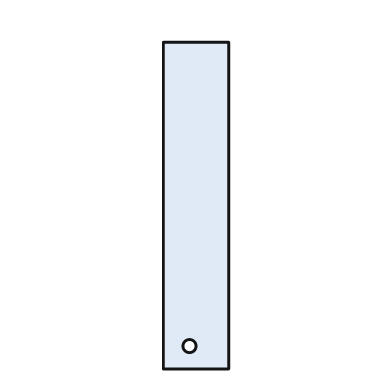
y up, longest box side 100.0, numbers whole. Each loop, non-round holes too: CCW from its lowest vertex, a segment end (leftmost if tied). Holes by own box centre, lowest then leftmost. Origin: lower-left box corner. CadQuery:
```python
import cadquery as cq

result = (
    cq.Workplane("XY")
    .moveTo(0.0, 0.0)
    .lineTo(20.0, 0.0)
    .lineTo(20.0, 100.0)
    .lineTo(0.0, 100.0)
    .close()
    .moveTo(8.0, 7.0)
    .circle(2.0)
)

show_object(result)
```